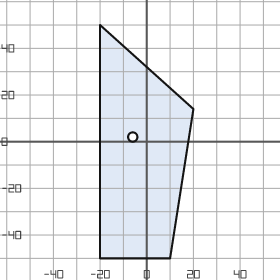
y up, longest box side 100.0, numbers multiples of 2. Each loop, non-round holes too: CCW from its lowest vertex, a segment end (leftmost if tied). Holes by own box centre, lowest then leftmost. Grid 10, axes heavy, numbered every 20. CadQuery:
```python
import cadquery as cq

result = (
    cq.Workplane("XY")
    .moveTo(-20.0, -50.0)
    .lineTo(10.0, -50.0)
    .lineTo(20.0, 14.0)
    .lineTo(-20.0, 50.0)
    .close()
    .moveTo(-6.0, 2.0)
    .circle(2.0)
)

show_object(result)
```